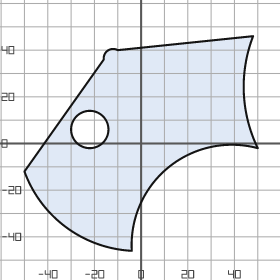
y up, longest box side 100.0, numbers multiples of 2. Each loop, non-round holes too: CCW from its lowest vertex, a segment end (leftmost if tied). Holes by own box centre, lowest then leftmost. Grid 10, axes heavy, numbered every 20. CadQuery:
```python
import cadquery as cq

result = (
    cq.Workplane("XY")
    .moveTo(-4.0, -46.0)
    .threePointArc((12.0, -10.0), (50.0, -2.0))
    .threePointArc((44.0, 22.0), (48.0, 46.0))
    .lineTo(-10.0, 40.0)
    .threePointArc((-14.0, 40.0), (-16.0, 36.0))
    .lineTo(-50.0, -12.0)
    .threePointArc((-32.0, -36.0), (-4.0, -46.0))
    .close()
    .moveTo(-22.0, 6.0)
    .circle(8.0)
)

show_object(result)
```